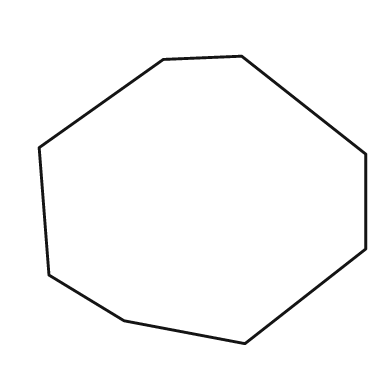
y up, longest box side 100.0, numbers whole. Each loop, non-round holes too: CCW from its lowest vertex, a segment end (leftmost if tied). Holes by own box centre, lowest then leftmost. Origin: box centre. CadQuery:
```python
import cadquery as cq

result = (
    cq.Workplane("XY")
    .moveTo(13.0, -44.0)
    .lineTo(50.0, -15.0)
    .lineTo(50.0, 14.0)
    .lineTo(12.0, 44.0)
    .lineTo(-12.0, 43.0)
    .lineTo(-50.0, 16.0)
    .lineTo(-47.0, -23.0)
    .lineTo(-24.0, -37.0)
    .close()
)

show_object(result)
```